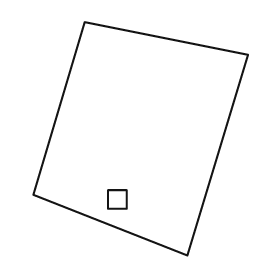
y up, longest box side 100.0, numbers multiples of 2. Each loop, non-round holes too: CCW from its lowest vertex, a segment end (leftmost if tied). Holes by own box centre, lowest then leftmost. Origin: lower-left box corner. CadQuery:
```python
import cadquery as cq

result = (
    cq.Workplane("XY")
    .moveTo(66.0, 0.0)
    .lineTo(92.0, 86.0)
    .lineTo(22.0, 100.0)
    .lineTo(0.0, 26.0)
    .close()
    .moveTo(32.0, 20.0)
    .lineTo(40.0, 20.0)
    .lineTo(40.0, 28.0)
    .lineTo(32.0, 28.0)
    .close()
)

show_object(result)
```